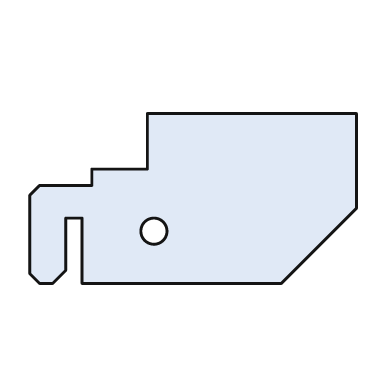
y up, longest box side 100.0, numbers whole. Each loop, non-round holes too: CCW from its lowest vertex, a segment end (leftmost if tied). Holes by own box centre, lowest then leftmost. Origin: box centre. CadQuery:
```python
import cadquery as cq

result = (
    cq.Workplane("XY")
    .moveTo(-47.0, -26.0)
    .lineTo(-43.0, -26.0)
    .lineTo(-39.0, -22.0)
    .lineTo(-39.0, -6.0)
    .lineTo(-34.0, -6.0)
    .lineTo(-34.0, -26.0)
    .lineTo(27.0, -26.0)
    .lineTo(50.0, -3.0)
    .lineTo(50.0, 26.0)
    .lineTo(-14.0, 26.0)
    .lineTo(-14.0, 9.0)
    .lineTo(-31.0, 9.0)
    .lineTo(-31.0, 4.0)
    .lineTo(-47.0, 4.0)
    .lineTo(-50.0, 1.0)
    .lineTo(-50.0, -23.0)
    .close()
    .moveTo(-12.0, -10.0)
    .circle(4.0)
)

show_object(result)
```